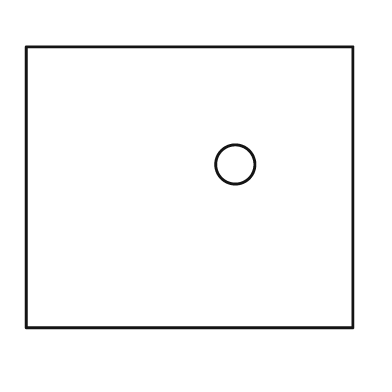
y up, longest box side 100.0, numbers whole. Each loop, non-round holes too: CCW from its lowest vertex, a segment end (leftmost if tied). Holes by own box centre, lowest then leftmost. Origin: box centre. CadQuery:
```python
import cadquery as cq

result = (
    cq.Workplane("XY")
    .moveTo(-50.0, -43.0)
    .lineTo(50.0, -43.0)
    .lineTo(50.0, 43.0)
    .lineTo(-50.0, 43.0)
    .close()
    .moveTo(14.0, 7.0)
    .circle(6.0)
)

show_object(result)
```